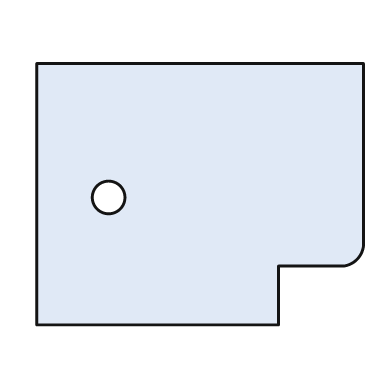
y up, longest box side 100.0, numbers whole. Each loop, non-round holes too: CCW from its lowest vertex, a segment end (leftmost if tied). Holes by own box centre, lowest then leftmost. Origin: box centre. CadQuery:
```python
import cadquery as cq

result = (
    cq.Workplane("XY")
    .moveTo(-50.0, -40.0)
    .lineTo(24.0, -40.0)
    .lineTo(24.0, -22.0)
    .lineTo(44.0, -22.0)
    .threePointArc((48.0, -20.0), (50.0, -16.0))
    .lineTo(50.0, 40.0)
    .lineTo(-50.0, 40.0)
    .close()
    .moveTo(-28.0, -1.0)
    .circle(5.0)
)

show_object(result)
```